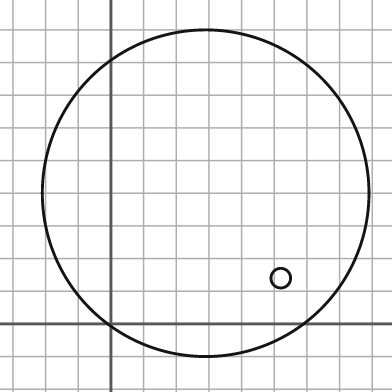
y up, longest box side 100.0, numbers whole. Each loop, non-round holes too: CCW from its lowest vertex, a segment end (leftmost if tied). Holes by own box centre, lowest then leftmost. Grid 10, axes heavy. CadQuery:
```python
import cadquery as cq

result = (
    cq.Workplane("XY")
    .moveTo(29.0, 40.0)
    .circle(50.0)
    .moveTo(52.0, 14.0)
    .circle(3.0)
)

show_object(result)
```